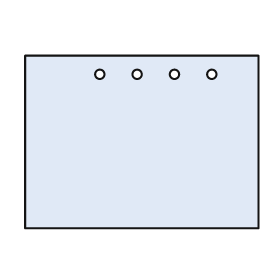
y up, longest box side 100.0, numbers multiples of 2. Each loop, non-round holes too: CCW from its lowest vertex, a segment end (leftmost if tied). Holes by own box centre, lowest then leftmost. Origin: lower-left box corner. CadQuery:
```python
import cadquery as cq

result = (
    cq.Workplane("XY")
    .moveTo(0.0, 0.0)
    .lineTo(100.0, 0.0)
    .lineTo(100.0, 74.0)
    .lineTo(0.0, 74.0)
    .close()
    .moveTo(32.0, 66.0)
    .circle(2.0)
    .moveTo(48.0, 66.0)
    .circle(2.0)
    .moveTo(64.0, 66.0)
    .circle(2.0)
    .moveTo(80.0, 66.0)
    .circle(2.0)
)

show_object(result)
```